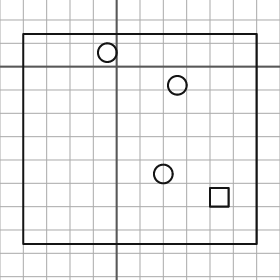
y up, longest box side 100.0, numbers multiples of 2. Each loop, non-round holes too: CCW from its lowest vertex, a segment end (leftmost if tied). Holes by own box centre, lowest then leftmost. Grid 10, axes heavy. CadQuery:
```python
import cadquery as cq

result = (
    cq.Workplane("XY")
    .moveTo(-40.0, -76.0)
    .lineTo(60.0, -76.0)
    .lineTo(60.0, 14.0)
    .lineTo(-40.0, 14.0)
    .close()
    .moveTo(40.0, -60.0)
    .lineTo(48.0, -60.0)
    .lineTo(48.0, -52.0)
    .lineTo(40.0, -52.0)
    .close()
    .moveTo(20.0, -46.0)
    .circle(4.0)
    .moveTo(26.0, -8.0)
    .circle(4.0)
    .moveTo(-4.0, 6.0)
    .circle(4.0)
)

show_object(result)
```